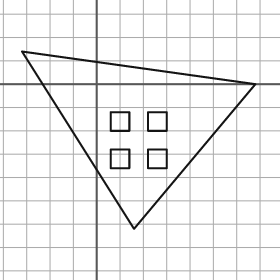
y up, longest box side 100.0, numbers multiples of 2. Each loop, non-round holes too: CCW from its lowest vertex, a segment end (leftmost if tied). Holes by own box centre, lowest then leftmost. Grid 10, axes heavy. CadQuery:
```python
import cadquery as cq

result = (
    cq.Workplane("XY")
    .moveTo(16.0, -62.0)
    .lineTo(68.0, 0.0)
    .lineTo(-32.0, 14.0)
    .close()
    .moveTo(6.0, -36.0)
    .lineTo(14.0, -36.0)
    .lineTo(14.0, -28.0)
    .lineTo(6.0, -28.0)
    .close()
    .moveTo(22.0, -36.0)
    .lineTo(30.0, -36.0)
    .lineTo(30.0, -28.0)
    .lineTo(22.0, -28.0)
    .close()
    .moveTo(6.0, -20.0)
    .lineTo(14.0, -20.0)
    .lineTo(14.0, -12.0)
    .lineTo(6.0, -12.0)
    .close()
    .moveTo(22.0, -20.0)
    .lineTo(30.0, -20.0)
    .lineTo(30.0, -12.0)
    .lineTo(22.0, -12.0)
    .close()
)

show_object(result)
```